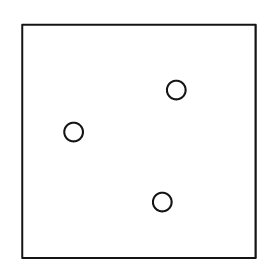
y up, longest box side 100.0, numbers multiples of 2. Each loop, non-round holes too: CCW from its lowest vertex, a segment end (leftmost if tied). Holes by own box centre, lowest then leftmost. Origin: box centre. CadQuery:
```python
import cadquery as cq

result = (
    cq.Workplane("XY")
    .moveTo(-50.0, -50.0)
    .lineTo(50.0, -50.0)
    .lineTo(50.0, 50.0)
    .lineTo(-50.0, 50.0)
    .close()
    .moveTo(10.0, -26.0)
    .circle(4.0)
    .moveTo(-28.0, 4.0)
    .circle(4.0)
    .moveTo(16.0, 22.0)
    .circle(4.0)
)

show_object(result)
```